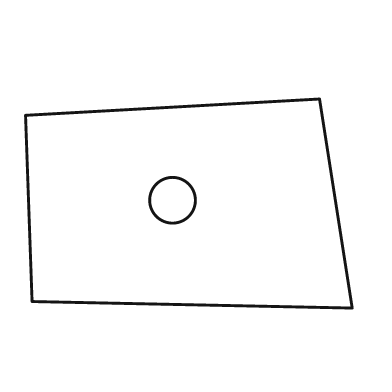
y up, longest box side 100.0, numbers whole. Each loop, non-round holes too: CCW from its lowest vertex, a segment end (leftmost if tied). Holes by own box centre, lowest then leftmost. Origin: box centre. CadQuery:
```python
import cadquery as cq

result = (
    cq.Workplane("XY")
    .moveTo(50.0, -32.0)
    .lineTo(40.0, 32.0)
    .lineTo(-50.0, 27.0)
    .lineTo(-48.0, -30.0)
    .close()
    .moveTo(-5.0, 1.0)
    .circle(7.0)
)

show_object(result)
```